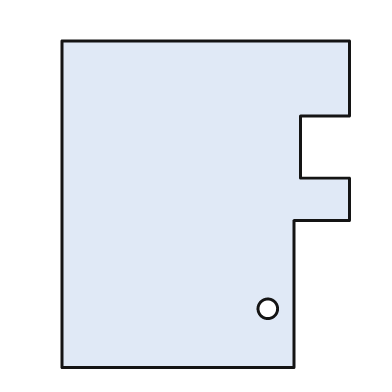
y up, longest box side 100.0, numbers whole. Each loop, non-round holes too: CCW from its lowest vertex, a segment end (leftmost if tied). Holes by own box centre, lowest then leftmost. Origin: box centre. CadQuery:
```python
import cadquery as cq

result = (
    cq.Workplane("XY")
    .moveTo(-44.0, -50.0)
    .lineTo(27.0, -50.0)
    .lineTo(27.0, -5.0)
    .lineTo(44.0, -5.0)
    .lineTo(44.0, 8.0)
    .lineTo(29.0, 8.0)
    .lineTo(29.0, 27.0)
    .lineTo(44.0, 27.0)
    .lineTo(44.0, 50.0)
    .lineTo(-44.0, 50.0)
    .close()
    .moveTo(19.0, -32.0)
    .circle(3.0)
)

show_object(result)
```